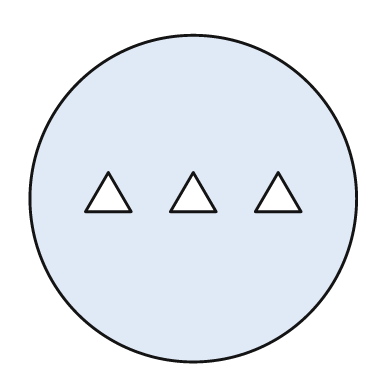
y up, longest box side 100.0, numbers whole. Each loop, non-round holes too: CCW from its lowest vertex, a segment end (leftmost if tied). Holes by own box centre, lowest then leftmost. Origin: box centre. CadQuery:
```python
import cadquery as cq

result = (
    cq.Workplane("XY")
    .moveTo(0.0, 0.0)
    .circle(50.0)
    .moveTo(-33.0, -4.0)
    .lineTo(-19.0, -4.0)
    .lineTo(-26.0, 8.0)
    .close()
    .moveTo(-7.0, -4.0)
    .lineTo(7.0, -4.0)
    .lineTo(0.0, 8.0)
    .close()
    .moveTo(19.0, -4.0)
    .lineTo(33.0, -4.0)
    .lineTo(26.0, 8.0)
    .close()
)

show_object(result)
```